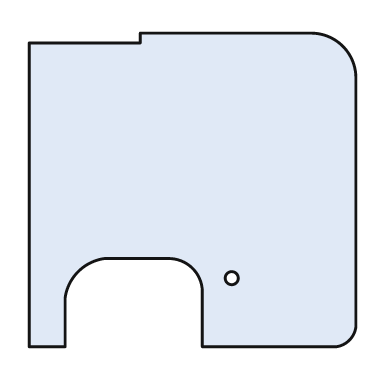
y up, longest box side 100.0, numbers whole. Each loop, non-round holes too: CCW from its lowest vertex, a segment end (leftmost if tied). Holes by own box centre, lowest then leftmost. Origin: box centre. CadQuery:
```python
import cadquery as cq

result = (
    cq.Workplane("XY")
    .moveTo(-50.0, -48.0)
    .lineTo(-39.0, -48.0)
    .lineTo(-39.0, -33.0)
    .threePointArc((-35.0, -25.0), (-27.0, -21.0))
    .lineTo(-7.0, -21.0)
    .threePointArc((0.0, -24.0), (3.0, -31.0))
    .lineTo(3.0, -48.0)
    .lineTo(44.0, -48.0)
    .threePointArc((48.0, -46.0), (50.0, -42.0))
    .lineTo(50.0, 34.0)
    .threePointArc((46.0, 44.0), (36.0, 48.0))
    .lineTo(-16.0, 48.0)
    .lineTo(-16.0, 45.0)
    .lineTo(-50.0, 45.0)
    .close()
    .moveTo(12.0, -27.0)
    .circle(2.0)
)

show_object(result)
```